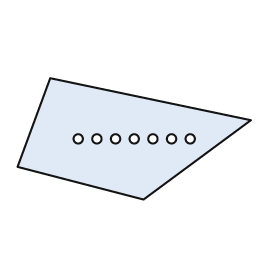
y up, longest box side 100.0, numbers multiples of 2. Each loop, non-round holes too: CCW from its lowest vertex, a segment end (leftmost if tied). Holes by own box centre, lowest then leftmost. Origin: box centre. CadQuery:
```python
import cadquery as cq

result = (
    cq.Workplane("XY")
    .moveTo(4.0, -26.0)
    .lineTo(50.0, 8.0)
    .lineTo(-36.0, 26.0)
    .lineTo(-50.0, -12.0)
    .close()
    .moveTo(-24.0, 0.0)
    .circle(2.0)
    .moveTo(-16.0, 0.0)
    .circle(2.0)
    .moveTo(-8.0, 0.0)
    .circle(2.0)
    .moveTo(0.0, 0.0)
    .circle(2.0)
    .moveTo(8.0, 0.0)
    .circle(2.0)
    .moveTo(16.0, 0.0)
    .circle(2.0)
    .moveTo(24.0, 0.0)
    .circle(2.0)
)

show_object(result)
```